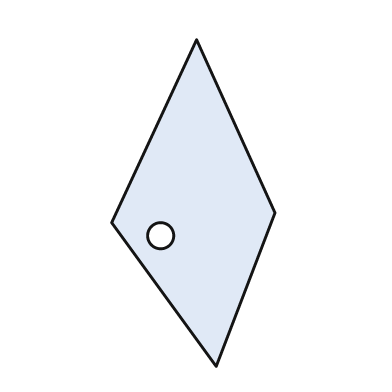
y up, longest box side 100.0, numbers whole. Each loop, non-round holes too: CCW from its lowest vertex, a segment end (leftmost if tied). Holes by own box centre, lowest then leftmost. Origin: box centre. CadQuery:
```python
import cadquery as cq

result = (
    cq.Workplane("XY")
    .moveTo(7.0, -50.0)
    .lineTo(25.0, -3.0)
    .lineTo(1.0, 50.0)
    .lineTo(-25.0, -6.0)
    .close()
    .moveTo(-10.0, -10.0)
    .circle(4.0)
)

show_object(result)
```